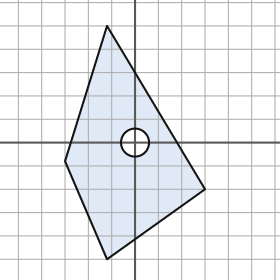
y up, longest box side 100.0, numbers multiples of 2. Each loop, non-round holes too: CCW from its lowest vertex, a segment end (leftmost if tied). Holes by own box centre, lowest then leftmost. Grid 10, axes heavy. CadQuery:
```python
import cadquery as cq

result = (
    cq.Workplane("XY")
    .moveTo(-12.0, -50.0)
    .lineTo(30.0, -20.0)
    .lineTo(-12.0, 50.0)
    .lineTo(-30.0, -8.0)
    .close()
    .moveTo(0.0, 0.0)
    .circle(6.0)
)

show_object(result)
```